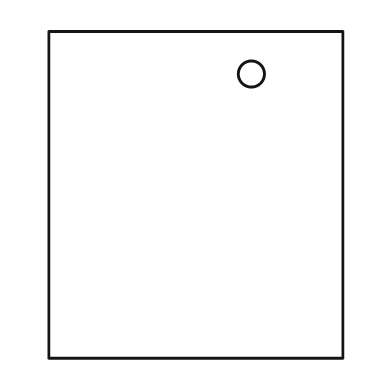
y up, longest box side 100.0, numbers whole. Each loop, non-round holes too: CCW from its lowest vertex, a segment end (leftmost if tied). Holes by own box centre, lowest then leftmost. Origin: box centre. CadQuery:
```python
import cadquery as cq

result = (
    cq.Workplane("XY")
    .moveTo(-45.0, -50.0)
    .lineTo(45.0, -50.0)
    .lineTo(45.0, 50.0)
    .lineTo(-45.0, 50.0)
    .close()
    .moveTo(17.0, 37.0)
    .circle(4.0)
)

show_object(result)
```